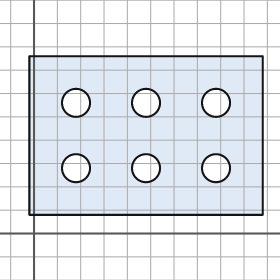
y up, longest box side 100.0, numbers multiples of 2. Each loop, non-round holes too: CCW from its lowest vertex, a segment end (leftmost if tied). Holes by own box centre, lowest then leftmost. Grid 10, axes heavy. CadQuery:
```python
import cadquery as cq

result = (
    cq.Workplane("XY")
    .moveTo(-2.0, 8.0)
    .lineTo(98.0, 8.0)
    .lineTo(98.0, 76.0)
    .lineTo(-2.0, 76.0)
    .close()
    .moveTo(18.0, 28.0)
    .circle(6.0)
    .moveTo(48.0, 28.0)
    .circle(6.0)
    .moveTo(78.0, 28.0)
    .circle(6.0)
    .moveTo(18.0, 56.0)
    .circle(6.0)
    .moveTo(48.0, 56.0)
    .circle(6.0)
    .moveTo(78.0, 56.0)
    .circle(6.0)
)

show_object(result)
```